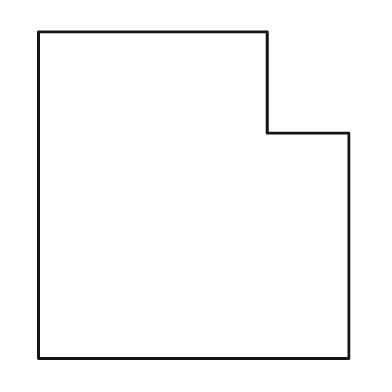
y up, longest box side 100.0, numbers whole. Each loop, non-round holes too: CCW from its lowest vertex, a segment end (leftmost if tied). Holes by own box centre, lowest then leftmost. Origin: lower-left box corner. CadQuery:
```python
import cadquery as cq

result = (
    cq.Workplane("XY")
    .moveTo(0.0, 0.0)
    .lineTo(95.0, 0.0)
    .lineTo(95.0, 69.0)
    .lineTo(70.0, 69.0)
    .lineTo(70.0, 100.0)
    .lineTo(0.0, 100.0)
    .close()
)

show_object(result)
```